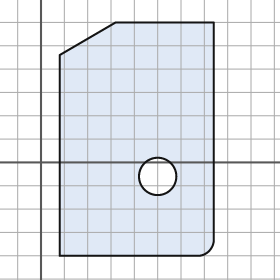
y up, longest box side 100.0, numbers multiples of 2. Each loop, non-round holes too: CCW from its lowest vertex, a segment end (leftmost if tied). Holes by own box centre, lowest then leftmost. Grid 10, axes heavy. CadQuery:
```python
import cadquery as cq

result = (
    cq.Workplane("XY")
    .moveTo(8.0, -40.0)
    .lineTo(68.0, -40.0)
    .threePointArc((72.0, -38.0), (74.0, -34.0))
    .lineTo(74.0, 60.0)
    .lineTo(32.0, 60.0)
    .lineTo(8.0, 46.0)
    .close()
    .moveTo(50.0, -6.0)
    .circle(8.0)
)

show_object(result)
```